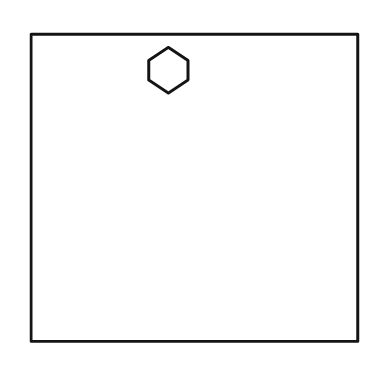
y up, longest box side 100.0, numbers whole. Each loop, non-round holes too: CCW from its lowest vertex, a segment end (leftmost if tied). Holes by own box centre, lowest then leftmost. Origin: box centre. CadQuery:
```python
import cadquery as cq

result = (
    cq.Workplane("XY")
    .moveTo(-50.0, -47.0)
    .lineTo(50.0, -47.0)
    .lineTo(50.0, 47.0)
    .lineTo(-50.0, 47.0)
    .close()
    .moveTo(-8.0, 29.0)
    .lineTo(-2.0, 33.0)
    .lineTo(-2.0, 39.0)
    .lineTo(-8.0, 43.0)
    .lineTo(-14.0, 39.0)
    .lineTo(-14.0, 33.0)
    .close()
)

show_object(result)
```